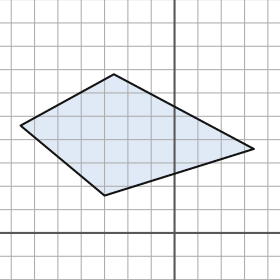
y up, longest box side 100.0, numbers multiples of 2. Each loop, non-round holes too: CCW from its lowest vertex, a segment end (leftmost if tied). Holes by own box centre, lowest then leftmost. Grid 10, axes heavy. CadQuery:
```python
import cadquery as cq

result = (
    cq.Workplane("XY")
    .moveTo(-30.0, 16.0)
    .lineTo(34.0, 36.0)
    .lineTo(-26.0, 68.0)
    .lineTo(-66.0, 46.0)
    .close()
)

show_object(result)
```